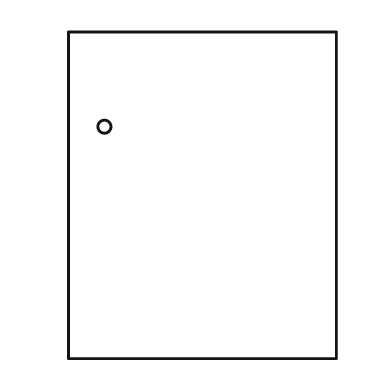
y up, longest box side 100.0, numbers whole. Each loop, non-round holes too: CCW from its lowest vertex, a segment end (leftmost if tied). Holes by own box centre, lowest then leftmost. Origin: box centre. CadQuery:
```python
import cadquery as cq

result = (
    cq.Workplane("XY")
    .moveTo(-41.0, -50.0)
    .lineTo(41.0, -50.0)
    .lineTo(41.0, 50.0)
    .lineTo(-41.0, 50.0)
    .close()
    .moveTo(-30.0, 21.0)
    .circle(2.0)
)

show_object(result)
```